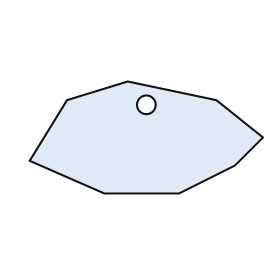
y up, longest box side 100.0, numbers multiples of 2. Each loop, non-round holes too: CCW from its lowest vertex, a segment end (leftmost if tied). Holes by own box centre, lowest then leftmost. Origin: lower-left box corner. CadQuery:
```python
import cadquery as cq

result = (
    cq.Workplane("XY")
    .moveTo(32.0, 0.0)
    .lineTo(64.0, 0.0)
    .lineTo(88.0, 12.0)
    .lineTo(100.0, 24.0)
    .lineTo(80.0, 40.0)
    .lineTo(42.0, 48.0)
    .lineTo(16.0, 40.0)
    .lineTo(0.0, 14.0)
    .close()
    .moveTo(50.0, 38.0)
    .circle(4.0)
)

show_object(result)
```